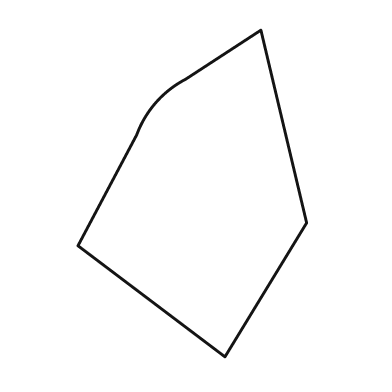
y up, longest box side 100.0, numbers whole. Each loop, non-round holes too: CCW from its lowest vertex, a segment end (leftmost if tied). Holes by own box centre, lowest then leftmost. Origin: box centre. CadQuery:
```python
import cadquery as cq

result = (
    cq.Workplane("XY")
    .moveTo(10.0, -50.0)
    .lineTo(35.0, -9.0)
    .lineTo(21.0, 50.0)
    .lineTo(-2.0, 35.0)
    .threePointArc((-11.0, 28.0), (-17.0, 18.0))
    .lineTo(-35.0, -16.0)
    .close()
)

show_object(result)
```